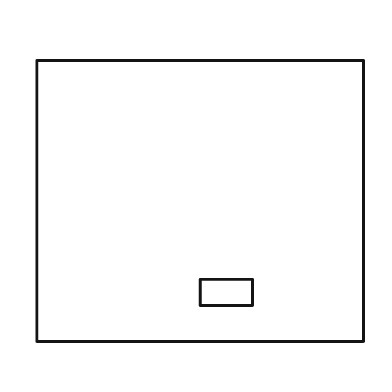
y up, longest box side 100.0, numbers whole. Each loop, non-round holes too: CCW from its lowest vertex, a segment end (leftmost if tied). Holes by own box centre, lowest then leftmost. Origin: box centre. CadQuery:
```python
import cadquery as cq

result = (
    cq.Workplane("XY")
    .moveTo(-50.0, -43.0)
    .lineTo(50.0, -43.0)
    .lineTo(50.0, 43.0)
    .lineTo(-50.0, 43.0)
    .close()
    .moveTo(0.0, -32.0)
    .lineTo(16.0, -32.0)
    .lineTo(16.0, -24.0)
    .lineTo(0.0, -24.0)
    .close()
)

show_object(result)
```